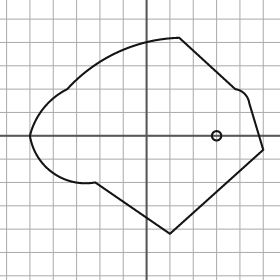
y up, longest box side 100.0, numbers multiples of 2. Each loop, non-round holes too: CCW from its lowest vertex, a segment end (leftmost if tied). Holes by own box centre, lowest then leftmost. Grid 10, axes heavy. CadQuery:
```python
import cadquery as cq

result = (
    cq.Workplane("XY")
    .moveTo(10.0, -42.0)
    .lineTo(50.0, -6.0)
    .lineTo(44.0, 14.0)
    .threePointArc((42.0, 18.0), (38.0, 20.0))
    .lineTo(14.0, 42.0)
    .threePointArc((-12.0, 36.0), (-34.0, 20.0))
    .threePointArc((-44.0, 12.0), (-50.0, 0.0))
    .threePointArc((-40.0, -16.0), (-22.0, -20.0))
    .close()
    .moveTo(30.0, 0.0)
    .circle(2.0)
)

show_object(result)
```